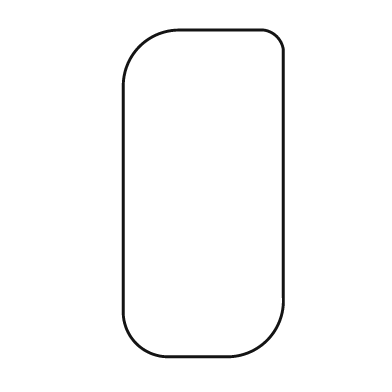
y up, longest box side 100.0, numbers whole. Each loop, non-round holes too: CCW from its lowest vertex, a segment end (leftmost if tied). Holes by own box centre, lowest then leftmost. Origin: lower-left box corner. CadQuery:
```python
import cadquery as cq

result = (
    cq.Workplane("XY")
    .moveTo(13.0, 0.0)
    .lineTo(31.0, 0.0)
    .threePointArc((44.0, 5.0), (49.0, 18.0))
    .lineTo(49.0, 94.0)
    .threePointArc((47.0, 98.0), (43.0, 100.0))
    .lineTo(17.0, 100.0)
    .threePointArc((5.0, 95.0), (0.0, 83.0))
    .lineTo(0.0, 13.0)
    .threePointArc((4.0, 4.0), (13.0, 0.0))
    .close()
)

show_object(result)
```